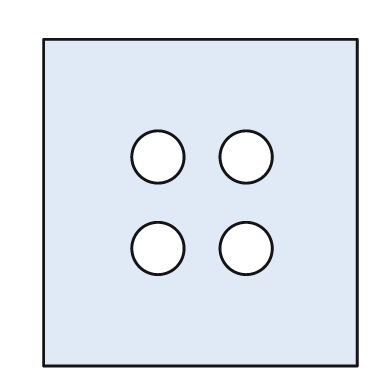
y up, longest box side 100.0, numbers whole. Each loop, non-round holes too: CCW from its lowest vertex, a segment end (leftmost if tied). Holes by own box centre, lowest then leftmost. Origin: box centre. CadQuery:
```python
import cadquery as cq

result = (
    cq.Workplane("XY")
    .moveTo(-48.0, -50.0)
    .lineTo(48.0, -50.0)
    .lineTo(48.0, 50.0)
    .lineTo(-48.0, 50.0)
    .close()
    .moveTo(-13.0, -14.0)
    .circle(8.0)
    .moveTo(14.0, -14.0)
    .circle(8.0)
    .moveTo(-13.0, 14.0)
    .circle(8.0)
    .moveTo(14.0, 14.0)
    .circle(8.0)
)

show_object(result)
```